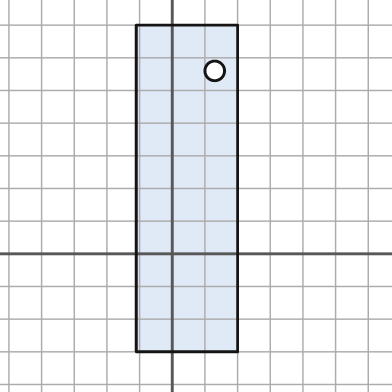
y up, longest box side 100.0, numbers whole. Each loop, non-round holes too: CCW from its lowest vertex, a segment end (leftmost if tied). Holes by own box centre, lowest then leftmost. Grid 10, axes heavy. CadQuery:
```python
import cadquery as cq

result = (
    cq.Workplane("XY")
    .moveTo(-11.0, -30.0)
    .lineTo(20.0, -30.0)
    .lineTo(20.0, 70.0)
    .lineTo(-11.0, 70.0)
    .close()
    .moveTo(13.0, 56.0)
    .circle(3.0)
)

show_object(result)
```